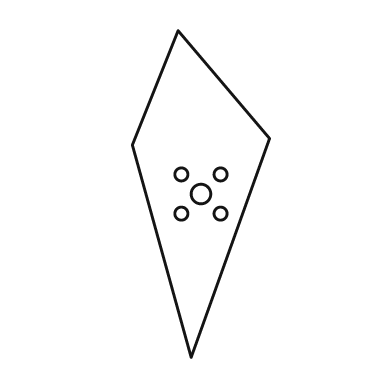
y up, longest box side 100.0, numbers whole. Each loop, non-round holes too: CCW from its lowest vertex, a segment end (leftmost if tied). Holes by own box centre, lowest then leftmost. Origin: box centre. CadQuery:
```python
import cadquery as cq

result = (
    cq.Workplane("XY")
    .moveTo(-3.0, -50.0)
    .lineTo(21.0, 17.0)
    .lineTo(-7.0, 50.0)
    .lineTo(-21.0, 15.0)
    .close()
    .moveTo(-6.0, -6.0)
    .circle(2.0)
    .moveTo(6.0, -6.0)
    .circle(2.0)
    .moveTo(0.0, 0.0)
    .circle(3.0)
    .moveTo(-6.0, 6.0)
    .circle(2.0)
    .moveTo(6.0, 6.0)
    .circle(2.0)
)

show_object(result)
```